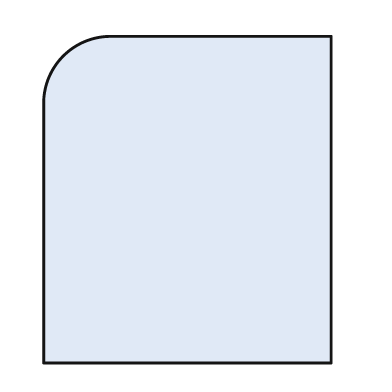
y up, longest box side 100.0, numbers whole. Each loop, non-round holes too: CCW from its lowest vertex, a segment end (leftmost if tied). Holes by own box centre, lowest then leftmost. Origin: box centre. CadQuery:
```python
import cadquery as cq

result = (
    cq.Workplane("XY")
    .moveTo(-44.0, -50.0)
    .lineTo(44.0, -50.0)
    .lineTo(44.0, 50.0)
    .lineTo(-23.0, 50.0)
    .threePointArc((-38.0, 44.0), (-44.0, 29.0))
    .close()
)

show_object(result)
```